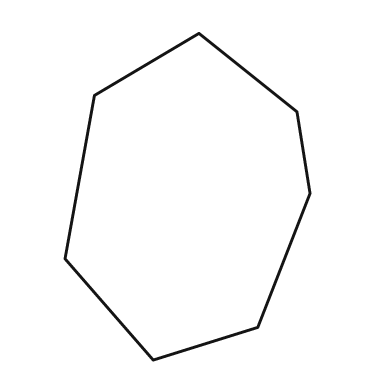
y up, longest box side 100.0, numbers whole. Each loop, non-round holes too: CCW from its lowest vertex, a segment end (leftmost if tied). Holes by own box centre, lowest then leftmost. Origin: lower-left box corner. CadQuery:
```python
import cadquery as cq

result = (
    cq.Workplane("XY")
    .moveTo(27.0, 0.0)
    .lineTo(59.0, 10.0)
    .lineTo(75.0, 51.0)
    .lineTo(71.0, 76.0)
    .lineTo(41.0, 100.0)
    .lineTo(9.0, 81.0)
    .lineTo(0.0, 31.0)
    .close()
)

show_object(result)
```